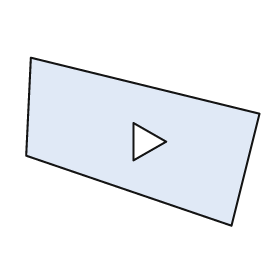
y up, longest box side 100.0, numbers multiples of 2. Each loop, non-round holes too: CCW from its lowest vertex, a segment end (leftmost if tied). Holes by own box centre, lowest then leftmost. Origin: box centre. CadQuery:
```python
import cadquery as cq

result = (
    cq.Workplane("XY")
    .moveTo(38.0, -36.0)
    .lineTo(50.0, 12.0)
    .lineTo(-48.0, 36.0)
    .lineTo(-50.0, -6.0)
    .close()
    .moveTo(-4.0, -8.0)
    .lineTo(10.0, 0.0)
    .lineTo(-4.0, 8.0)
    .close()
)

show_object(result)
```